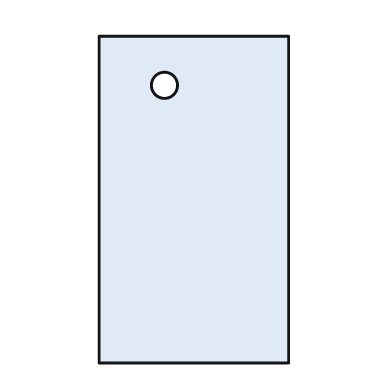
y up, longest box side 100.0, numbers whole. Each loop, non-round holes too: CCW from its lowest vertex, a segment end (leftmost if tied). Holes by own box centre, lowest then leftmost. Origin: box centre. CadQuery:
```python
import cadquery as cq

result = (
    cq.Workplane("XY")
    .moveTo(-29.0, -50.0)
    .lineTo(29.0, -50.0)
    .lineTo(29.0, 50.0)
    .lineTo(-29.0, 50.0)
    .close()
    .moveTo(-9.0, 35.0)
    .circle(4.0)
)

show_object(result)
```